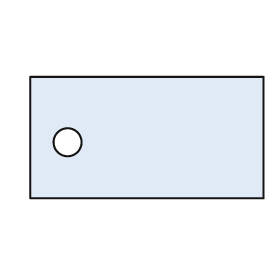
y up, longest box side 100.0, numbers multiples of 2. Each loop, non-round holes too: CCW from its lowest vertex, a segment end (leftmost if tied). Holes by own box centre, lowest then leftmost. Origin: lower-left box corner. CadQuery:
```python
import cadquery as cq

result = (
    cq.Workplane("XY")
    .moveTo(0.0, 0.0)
    .lineTo(100.0, 0.0)
    .lineTo(100.0, 52.0)
    .lineTo(0.0, 52.0)
    .close()
    .moveTo(16.0, 24.0)
    .circle(6.0)
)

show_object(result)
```